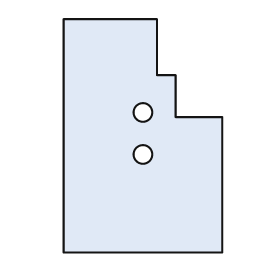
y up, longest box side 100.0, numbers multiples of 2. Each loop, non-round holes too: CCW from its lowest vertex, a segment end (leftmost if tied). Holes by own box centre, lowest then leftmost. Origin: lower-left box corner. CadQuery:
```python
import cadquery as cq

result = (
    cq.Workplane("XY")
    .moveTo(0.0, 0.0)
    .lineTo(68.0, 0.0)
    .lineTo(68.0, 58.0)
    .lineTo(48.0, 58.0)
    .lineTo(48.0, 76.0)
    .lineTo(40.0, 76.0)
    .lineTo(40.0, 100.0)
    .lineTo(0.0, 100.0)
    .close()
    .moveTo(34.0, 42.0)
    .circle(4.0)
    .moveTo(34.0, 60.0)
    .circle(4.0)
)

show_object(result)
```